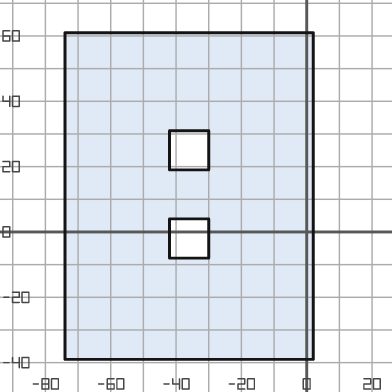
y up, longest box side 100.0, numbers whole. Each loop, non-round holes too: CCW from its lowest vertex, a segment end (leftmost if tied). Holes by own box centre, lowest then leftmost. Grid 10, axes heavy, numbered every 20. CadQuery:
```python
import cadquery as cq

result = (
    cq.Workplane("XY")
    .moveTo(-74.0, -39.0)
    .lineTo(2.0, -39.0)
    .lineTo(2.0, 61.0)
    .lineTo(-74.0, 61.0)
    .close()
    .moveTo(-42.0, -8.0)
    .lineTo(-30.0, -8.0)
    .lineTo(-30.0, 4.0)
    .lineTo(-42.0, 4.0)
    .close()
    .moveTo(-42.0, 19.0)
    .lineTo(-30.0, 19.0)
    .lineTo(-30.0, 31.0)
    .lineTo(-42.0, 31.0)
    .close()
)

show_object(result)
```